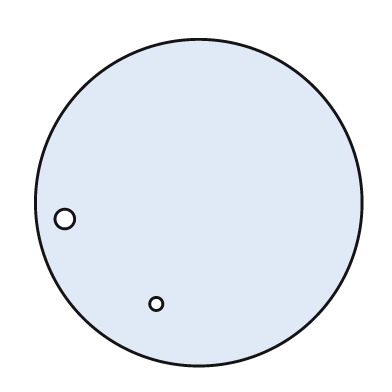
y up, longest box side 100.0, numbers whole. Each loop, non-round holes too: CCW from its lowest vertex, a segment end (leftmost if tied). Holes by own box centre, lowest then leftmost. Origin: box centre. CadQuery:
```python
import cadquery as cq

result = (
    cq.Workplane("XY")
    .moveTo(0.0, 0.0)
    .circle(50.0)
    .moveTo(-13.0, -31.0)
    .circle(2.0)
    .moveTo(-41.0, -5.0)
    .circle(3.0)
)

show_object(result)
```